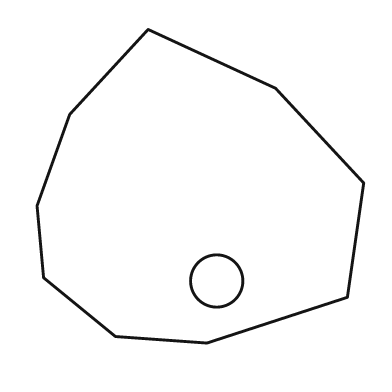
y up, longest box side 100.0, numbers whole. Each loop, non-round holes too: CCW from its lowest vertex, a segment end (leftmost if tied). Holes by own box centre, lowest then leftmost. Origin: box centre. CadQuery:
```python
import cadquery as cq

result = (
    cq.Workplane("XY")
    .moveTo(2.0, -48.0)
    .lineTo(45.0, -34.0)
    .lineTo(50.0, 1.0)
    .lineTo(23.0, 30.0)
    .lineTo(-16.0, 48.0)
    .lineTo(-40.0, 22.0)
    .lineTo(-50.0, -6.0)
    .lineTo(-48.0, -28.0)
    .lineTo(-26.0, -46.0)
    .close()
    .moveTo(5.0, -29.0)
    .circle(8.0)
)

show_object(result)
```